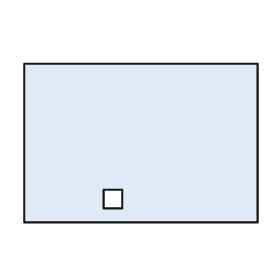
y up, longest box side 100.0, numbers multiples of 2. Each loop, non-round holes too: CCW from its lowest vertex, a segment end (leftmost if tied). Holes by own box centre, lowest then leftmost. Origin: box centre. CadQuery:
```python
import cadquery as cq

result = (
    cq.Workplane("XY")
    .moveTo(-50.0, -34.0)
    .lineTo(50.0, -34.0)
    .lineTo(50.0, 34.0)
    .lineTo(-50.0, 34.0)
    .close()
    .moveTo(-16.0, -28.0)
    .lineTo(-8.0, -28.0)
    .lineTo(-8.0, -20.0)
    .lineTo(-16.0, -20.0)
    .close()
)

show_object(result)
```